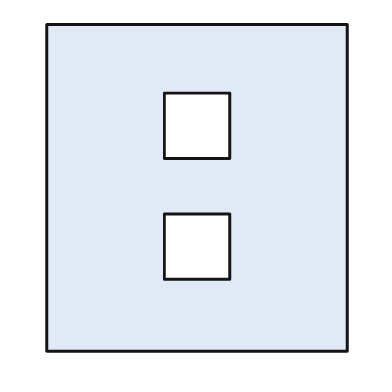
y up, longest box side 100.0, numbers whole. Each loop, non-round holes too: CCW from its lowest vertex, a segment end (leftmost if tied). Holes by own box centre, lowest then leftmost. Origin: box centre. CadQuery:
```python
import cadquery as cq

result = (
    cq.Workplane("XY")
    .moveTo(-46.0, -50.0)
    .lineTo(46.0, -50.0)
    .lineTo(46.0, 50.0)
    .lineTo(-46.0, 50.0)
    .close()
    .moveTo(-10.0, -28.0)
    .lineTo(10.0, -28.0)
    .lineTo(10.0, -8.0)
    .lineTo(-10.0, -8.0)
    .close()
    .moveTo(-10.0, 9.0)
    .lineTo(10.0, 9.0)
    .lineTo(10.0, 29.0)
    .lineTo(-10.0, 29.0)
    .close()
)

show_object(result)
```